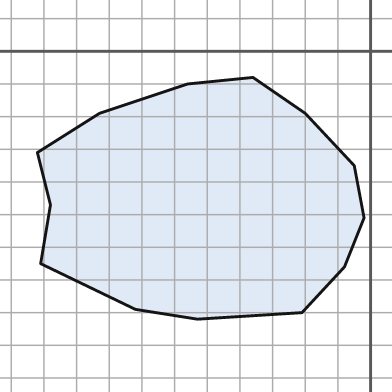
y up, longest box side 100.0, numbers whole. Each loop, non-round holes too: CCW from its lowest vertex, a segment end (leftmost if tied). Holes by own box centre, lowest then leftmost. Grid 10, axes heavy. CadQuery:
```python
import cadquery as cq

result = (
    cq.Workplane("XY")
    .moveTo(-53.0, -82.0)
    .lineTo(-21.0, -80.0)
    .lineTo(-8.0, -66.0)
    .lineTo(-2.0, -51.0)
    .lineTo(-5.0, -35.0)
    .lineTo(-20.0, -19.0)
    .lineTo(-36.0, -8.0)
    .lineTo(-56.0, -10.0)
    .lineTo(-83.0, -19.0)
    .lineTo(-102.0, -31.0)
    .lineTo(-98.0, -47.0)
    .lineTo(-101.0, -65.0)
    .lineTo(-72.0, -79.0)
    .close()
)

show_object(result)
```